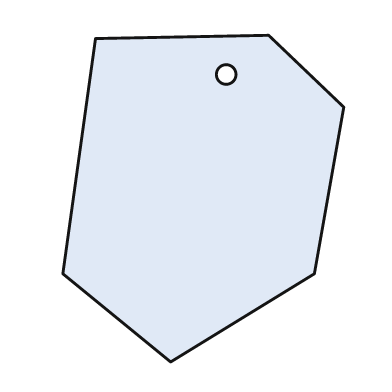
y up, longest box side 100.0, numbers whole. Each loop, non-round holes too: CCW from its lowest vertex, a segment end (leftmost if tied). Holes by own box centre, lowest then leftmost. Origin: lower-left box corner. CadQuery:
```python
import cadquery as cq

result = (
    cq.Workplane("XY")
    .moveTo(33.0, 0.0)
    .lineTo(77.0, 27.0)
    .lineTo(86.0, 78.0)
    .lineTo(63.0, 100.0)
    .lineTo(10.0, 99.0)
    .lineTo(0.0, 27.0)
    .close()
    .moveTo(50.0, 88.0)
    .circle(3.0)
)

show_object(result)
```